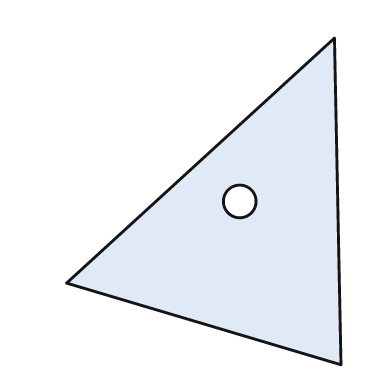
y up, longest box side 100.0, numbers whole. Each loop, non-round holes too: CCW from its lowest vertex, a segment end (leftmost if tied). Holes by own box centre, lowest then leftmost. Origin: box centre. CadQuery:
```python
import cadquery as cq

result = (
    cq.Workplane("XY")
    .moveTo(42.0, -50.0)
    .lineTo(40.0, 50.0)
    .lineTo(-42.0, -25.0)
    .close()
    .moveTo(11.0, 0.0)
    .circle(5.0)
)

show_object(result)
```